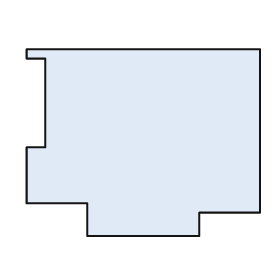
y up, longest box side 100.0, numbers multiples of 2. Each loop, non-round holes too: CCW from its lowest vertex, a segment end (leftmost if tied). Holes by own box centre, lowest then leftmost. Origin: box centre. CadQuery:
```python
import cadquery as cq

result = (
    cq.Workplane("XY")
    .moveTo(-24.0, -40.0)
    .lineTo(24.0, -40.0)
    .lineTo(24.0, -30.0)
    .lineTo(50.0, -30.0)
    .lineTo(50.0, 40.0)
    .lineTo(-50.0, 40.0)
    .lineTo(-50.0, 36.0)
    .lineTo(-42.0, 36.0)
    .lineTo(-42.0, -2.0)
    .lineTo(-50.0, -2.0)
    .lineTo(-50.0, -26.0)
    .lineTo(-24.0, -26.0)
    .close()
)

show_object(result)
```